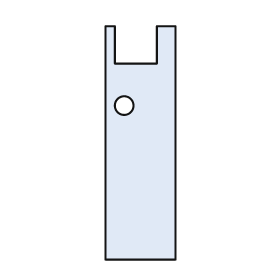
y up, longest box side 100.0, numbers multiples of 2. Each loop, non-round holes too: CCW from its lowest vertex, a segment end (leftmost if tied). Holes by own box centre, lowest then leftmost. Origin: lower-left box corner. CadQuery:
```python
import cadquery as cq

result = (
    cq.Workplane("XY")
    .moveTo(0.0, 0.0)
    .lineTo(30.0, 0.0)
    .lineTo(30.0, 100.0)
    .lineTo(22.0, 100.0)
    .lineTo(22.0, 84.0)
    .lineTo(4.0, 84.0)
    .lineTo(4.0, 100.0)
    .lineTo(0.0, 100.0)
    .close()
    .moveTo(8.0, 66.0)
    .circle(4.0)
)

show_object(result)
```